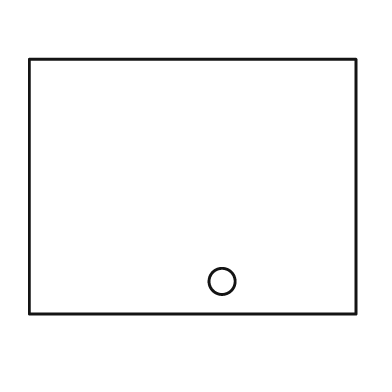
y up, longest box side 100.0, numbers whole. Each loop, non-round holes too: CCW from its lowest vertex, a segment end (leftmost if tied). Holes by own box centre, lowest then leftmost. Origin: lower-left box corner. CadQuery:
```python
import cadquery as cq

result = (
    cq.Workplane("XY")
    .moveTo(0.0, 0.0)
    .lineTo(100.0, 0.0)
    .lineTo(100.0, 78.0)
    .lineTo(0.0, 78.0)
    .close()
    .moveTo(59.0, 10.0)
    .circle(4.0)
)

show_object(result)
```